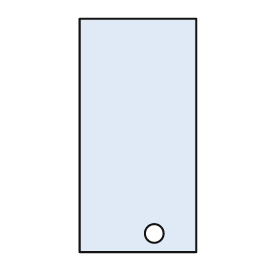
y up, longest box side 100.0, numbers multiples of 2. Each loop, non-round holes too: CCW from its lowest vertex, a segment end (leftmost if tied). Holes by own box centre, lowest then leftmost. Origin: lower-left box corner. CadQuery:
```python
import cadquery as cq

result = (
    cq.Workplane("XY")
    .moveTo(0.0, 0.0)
    .lineTo(50.0, 0.0)
    .lineTo(50.0, 100.0)
    .lineTo(0.0, 100.0)
    .close()
    .moveTo(32.0, 8.0)
    .circle(4.0)
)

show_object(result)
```